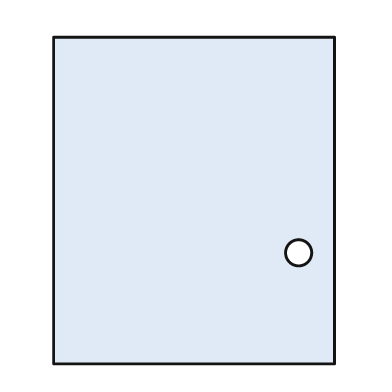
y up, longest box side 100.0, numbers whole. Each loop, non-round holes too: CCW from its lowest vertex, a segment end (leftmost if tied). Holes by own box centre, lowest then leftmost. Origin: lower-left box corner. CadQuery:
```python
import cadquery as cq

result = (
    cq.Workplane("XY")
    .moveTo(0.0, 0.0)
    .lineTo(86.0, 0.0)
    .lineTo(86.0, 100.0)
    .lineTo(0.0, 100.0)
    .close()
    .moveTo(75.0, 34.0)
    .circle(4.0)
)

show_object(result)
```